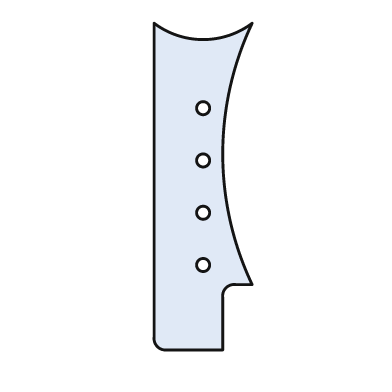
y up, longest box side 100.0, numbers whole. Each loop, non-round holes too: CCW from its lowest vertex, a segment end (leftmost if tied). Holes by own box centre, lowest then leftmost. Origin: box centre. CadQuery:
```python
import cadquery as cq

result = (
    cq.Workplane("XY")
    .moveTo(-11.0, -50.0)
    .lineTo(6.0, -50.0)
    .lineTo(6.0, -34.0)
    .threePointArc((7.0, -31.0), (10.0, -30.0))
    .lineTo(15.0, -30.0)
    .threePointArc((6.0, 10.0), (15.0, 50.0))
    .threePointArc((0.0, 45.0), (-15.0, 50.0))
    .lineTo(-15.0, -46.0)
    .threePointArc((-14.0, -49.0), (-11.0, -50.0))
    .close()
    .moveTo(0.0, -24.0)
    .circle(2.0)
    .moveTo(0.0, -8.0)
    .circle(2.0)
    .moveTo(0.0, 8.0)
    .circle(2.0)
    .moveTo(0.0, 24.0)
    .circle(2.0)
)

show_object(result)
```